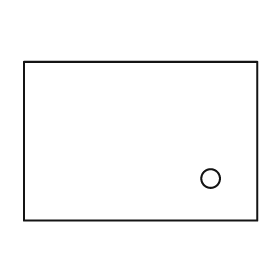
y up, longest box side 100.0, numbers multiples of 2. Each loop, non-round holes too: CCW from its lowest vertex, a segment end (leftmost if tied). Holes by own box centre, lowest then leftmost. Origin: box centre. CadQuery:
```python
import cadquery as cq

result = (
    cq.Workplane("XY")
    .moveTo(-50.0, -34.0)
    .lineTo(50.0, -34.0)
    .lineTo(50.0, 34.0)
    .lineTo(-50.0, 34.0)
    .close()
    .moveTo(30.0, -16.0)
    .circle(4.0)
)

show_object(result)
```